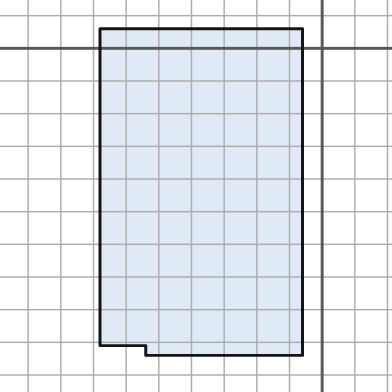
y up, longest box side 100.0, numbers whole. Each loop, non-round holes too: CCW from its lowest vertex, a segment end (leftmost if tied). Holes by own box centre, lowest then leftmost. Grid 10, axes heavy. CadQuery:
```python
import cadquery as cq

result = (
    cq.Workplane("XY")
    .moveTo(-54.0, -94.0)
    .lineTo(-6.0, -94.0)
    .lineTo(-6.0, 6.0)
    .lineTo(-68.0, 6.0)
    .lineTo(-68.0, -91.0)
    .lineTo(-54.0, -91.0)
    .close()
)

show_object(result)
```